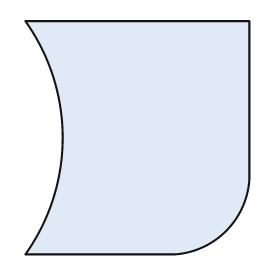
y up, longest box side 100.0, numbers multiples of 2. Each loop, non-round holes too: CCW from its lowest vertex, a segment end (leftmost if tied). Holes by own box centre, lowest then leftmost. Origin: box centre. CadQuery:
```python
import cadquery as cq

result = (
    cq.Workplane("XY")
    .moveTo(-48.0, -50.0)
    .lineTo(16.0, -50.0)
    .threePointArc((38.0, -40.0), (48.0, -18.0))
    .lineTo(48.0, 50.0)
    .lineTo(-48.0, 50.0)
    .threePointArc((-32.0, 0.0), (-48.0, -50.0))
    .close()
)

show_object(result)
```